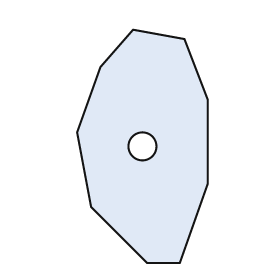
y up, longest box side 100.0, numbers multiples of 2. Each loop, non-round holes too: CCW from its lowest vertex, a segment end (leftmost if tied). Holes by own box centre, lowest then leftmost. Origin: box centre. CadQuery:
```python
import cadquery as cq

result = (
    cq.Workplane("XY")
    .moveTo(2.0, -50.0)
    .lineTo(16.0, -50.0)
    .lineTo(28.0, -16.0)
    .lineTo(28.0, 20.0)
    .lineTo(18.0, 46.0)
    .lineTo(-4.0, 50.0)
    .lineTo(-18.0, 34.0)
    .lineTo(-28.0, 6.0)
    .lineTo(-22.0, -26.0)
    .close()
    .moveTo(0.0, 0.0)
    .circle(6.0)
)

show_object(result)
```